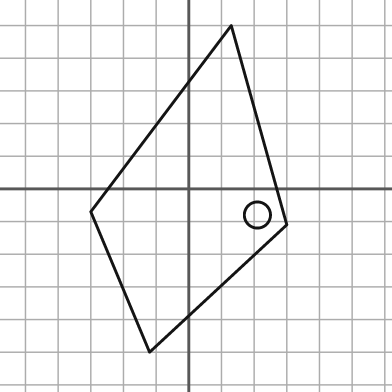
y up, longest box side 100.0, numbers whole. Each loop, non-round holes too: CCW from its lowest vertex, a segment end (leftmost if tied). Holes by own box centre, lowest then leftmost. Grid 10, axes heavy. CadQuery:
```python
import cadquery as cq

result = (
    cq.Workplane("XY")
    .moveTo(-12.0, -50.0)
    .lineTo(30.0, -11.0)
    .lineTo(13.0, 50.0)
    .lineTo(-30.0, -7.0)
    .close()
    .moveTo(21.0, -8.0)
    .circle(4.0)
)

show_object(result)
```